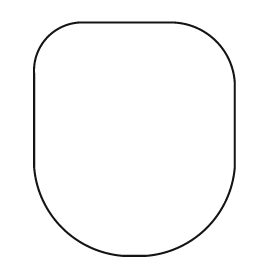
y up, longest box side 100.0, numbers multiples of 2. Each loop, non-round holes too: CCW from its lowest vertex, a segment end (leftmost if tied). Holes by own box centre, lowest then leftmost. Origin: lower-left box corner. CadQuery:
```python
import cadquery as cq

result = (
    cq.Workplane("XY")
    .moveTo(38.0, 0.0)
    .lineTo(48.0, 0.0)
    .threePointArc((74.0, 12.0), (86.0, 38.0))
    .lineTo(86.0, 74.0)
    .threePointArc((78.0, 92.0), (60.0, 100.0))
    .lineTo(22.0, 100.0)
    .threePointArc((6.0, 94.0), (0.0, 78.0))
    .lineTo(0.0, 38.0)
    .threePointArc((12.0, 12.0), (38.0, 0.0))
    .close()
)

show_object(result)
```